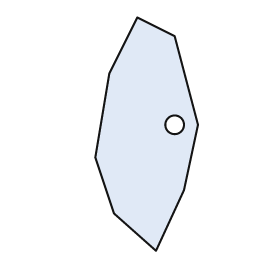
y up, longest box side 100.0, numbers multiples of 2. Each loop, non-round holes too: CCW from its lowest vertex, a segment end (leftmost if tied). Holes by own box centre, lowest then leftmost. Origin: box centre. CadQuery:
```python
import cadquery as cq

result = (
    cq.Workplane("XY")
    .moveTo(4.0, -50.0)
    .lineTo(16.0, -24.0)
    .lineTo(22.0, 4.0)
    .lineTo(12.0, 42.0)
    .lineTo(-4.0, 50.0)
    .lineTo(-16.0, 26.0)
    .lineTo(-22.0, -10.0)
    .lineTo(-14.0, -34.0)
    .close()
    .moveTo(12.0, 4.0)
    .circle(4.0)
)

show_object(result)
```